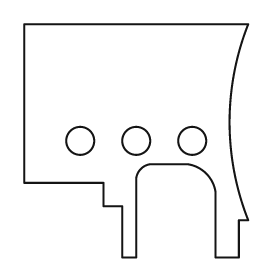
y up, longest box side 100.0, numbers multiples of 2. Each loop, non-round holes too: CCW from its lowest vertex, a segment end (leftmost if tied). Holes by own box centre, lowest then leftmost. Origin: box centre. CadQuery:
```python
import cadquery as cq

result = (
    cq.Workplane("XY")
    .moveTo(-6.0, -50.0)
    .lineTo(0.0, -50.0)
    .lineTo(0.0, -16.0)
    .threePointArc((2.0, -12.0), (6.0, -10.0))
    .lineTo(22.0, -10.0)
    .threePointArc((30.0, -14.0), (34.0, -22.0))
    .lineTo(34.0, -50.0)
    .lineTo(44.0, -50.0)
    .lineTo(44.0, -34.0)
    .lineTo(48.0, -34.0)
    .threePointArc((40.0, 8.0), (48.0, 50.0))
    .lineTo(-48.0, 50.0)
    .lineTo(-48.0, -18.0)
    .lineTo(-14.0, -18.0)
    .lineTo(-14.0, -28.0)
    .lineTo(-6.0, -28.0)
    .close()
    .moveTo(-24.0, 0.0)
    .circle(6.0)
    .moveTo(0.0, 0.0)
    .circle(6.0)
    .moveTo(24.0, 0.0)
    .circle(6.0)
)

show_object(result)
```